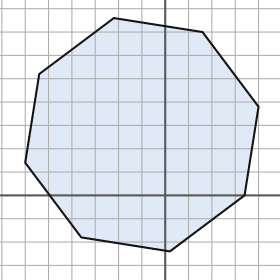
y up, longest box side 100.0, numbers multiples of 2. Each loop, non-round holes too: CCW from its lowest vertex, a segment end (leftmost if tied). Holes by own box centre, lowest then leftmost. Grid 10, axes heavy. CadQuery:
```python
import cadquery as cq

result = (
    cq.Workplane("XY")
    .moveTo(2.0, -24.0)
    .lineTo(34.0, 0.0)
    .lineTo(40.0, 38.0)
    .lineTo(16.0, 70.0)
    .lineTo(-22.0, 76.0)
    .lineTo(-54.0, 52.0)
    .lineTo(-60.0, 14.0)
    .lineTo(-36.0, -18.0)
    .close()
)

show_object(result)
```